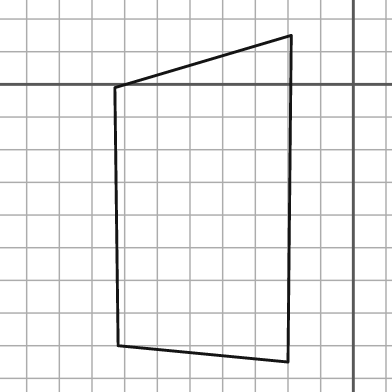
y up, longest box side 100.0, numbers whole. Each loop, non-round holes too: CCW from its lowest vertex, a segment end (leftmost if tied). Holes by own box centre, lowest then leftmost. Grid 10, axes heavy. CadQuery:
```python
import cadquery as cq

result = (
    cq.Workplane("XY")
    .moveTo(-20.0, -85.0)
    .lineTo(-19.0, 15.0)
    .lineTo(-73.0, -1.0)
    .lineTo(-72.0, -80.0)
    .close()
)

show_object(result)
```